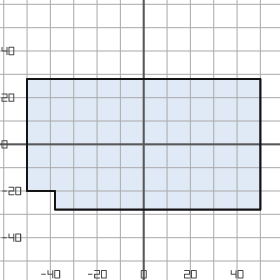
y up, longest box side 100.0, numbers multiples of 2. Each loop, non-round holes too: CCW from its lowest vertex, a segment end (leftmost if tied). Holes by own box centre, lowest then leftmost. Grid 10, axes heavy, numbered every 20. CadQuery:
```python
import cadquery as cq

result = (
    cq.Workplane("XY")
    .moveTo(-38.0, -28.0)
    .lineTo(50.0, -28.0)
    .lineTo(50.0, 28.0)
    .lineTo(-50.0, 28.0)
    .lineTo(-50.0, -20.0)
    .lineTo(-38.0, -20.0)
    .close()
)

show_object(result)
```